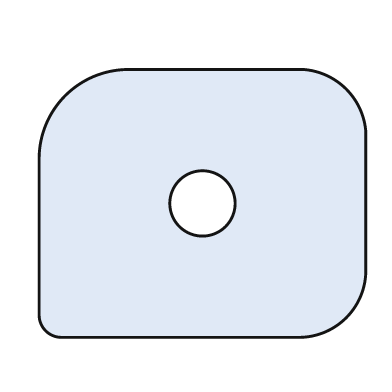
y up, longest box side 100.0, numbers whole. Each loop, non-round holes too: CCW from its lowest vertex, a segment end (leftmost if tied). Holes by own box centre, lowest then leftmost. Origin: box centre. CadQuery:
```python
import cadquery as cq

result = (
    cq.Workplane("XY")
    .moveTo(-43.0, -41.0)
    .lineTo(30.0, -41.0)
    .threePointArc((44.0, -35.0), (50.0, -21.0))
    .lineTo(50.0, 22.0)
    .threePointArc((44.0, 35.0), (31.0, 41.0))
    .lineTo(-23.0, 41.0)
    .threePointArc((-42.0, 33.0), (-50.0, 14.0))
    .lineTo(-50.0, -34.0)
    .threePointArc((-48.0, -39.0), (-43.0, -41.0))
    .close()
    .moveTo(0.0, 0.0)
    .circle(10.0)
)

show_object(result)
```